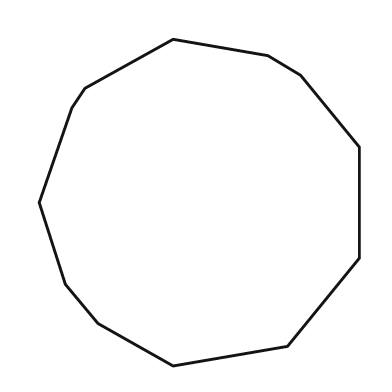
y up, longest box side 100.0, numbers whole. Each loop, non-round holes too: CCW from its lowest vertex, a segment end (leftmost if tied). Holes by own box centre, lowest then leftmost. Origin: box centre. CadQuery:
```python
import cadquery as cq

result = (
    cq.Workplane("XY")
    .moveTo(-8.0, -50.0)
    .lineTo(27.0, -44.0)
    .lineTo(49.0, -17.0)
    .lineTo(49.0, 17.0)
    .lineTo(31.0, 39.0)
    .lineTo(21.0, 45.0)
    .lineTo(-8.0, 50.0)
    .lineTo(-35.0, 35.0)
    .lineTo(-39.0, 29.0)
    .lineTo(-49.0, 0.0)
    .lineTo(-41.0, -25.0)
    .lineTo(-31.0, -37.0)
    .close()
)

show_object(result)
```